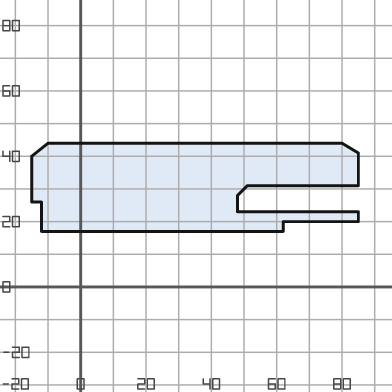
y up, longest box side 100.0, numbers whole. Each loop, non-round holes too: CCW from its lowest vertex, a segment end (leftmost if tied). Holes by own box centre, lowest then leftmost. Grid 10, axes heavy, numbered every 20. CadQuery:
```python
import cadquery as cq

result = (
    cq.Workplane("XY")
    .moveTo(-12.0, 17.0)
    .lineTo(62.0, 17.0)
    .lineTo(62.0, 20.0)
    .lineTo(85.0, 20.0)
    .lineTo(85.0, 23.0)
    .lineTo(48.0, 23.0)
    .lineTo(48.0, 28.0)
    .lineTo(51.0, 31.0)
    .lineTo(85.0, 31.0)
    .lineTo(85.0, 41.0)
    .lineTo(80.0, 44.0)
    .lineTo(-10.0, 44.0)
    .lineTo(-15.0, 40.0)
    .lineTo(-15.0, 26.0)
    .lineTo(-12.0, 26.0)
    .close()
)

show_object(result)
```